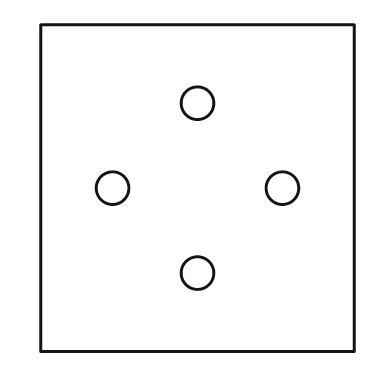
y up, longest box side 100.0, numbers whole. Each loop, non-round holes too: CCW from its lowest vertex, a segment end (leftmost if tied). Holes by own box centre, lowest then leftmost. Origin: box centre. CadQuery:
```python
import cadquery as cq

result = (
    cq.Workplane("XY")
    .moveTo(-48.0, -50.0)
    .lineTo(48.0, -50.0)
    .lineTo(48.0, 50.0)
    .lineTo(-48.0, 50.0)
    .close()
    .moveTo(0.0, -26.0)
    .circle(5.0)
    .moveTo(-26.0, 0.0)
    .circle(5.0)
    .moveTo(26.0, 0.0)
    .circle(5.0)
    .moveTo(0.0, 26.0)
    .circle(5.0)
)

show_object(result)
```